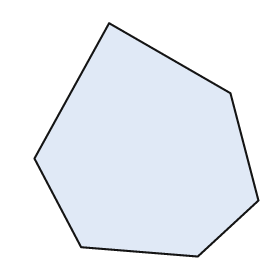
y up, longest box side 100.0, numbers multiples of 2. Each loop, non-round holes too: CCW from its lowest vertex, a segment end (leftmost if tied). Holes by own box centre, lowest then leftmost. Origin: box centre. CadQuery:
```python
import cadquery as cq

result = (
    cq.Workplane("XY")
    .moveTo(22.0, -50.0)
    .lineTo(48.0, -26.0)
    .lineTo(36.0, 20.0)
    .lineTo(-16.0, 50.0)
    .lineTo(-48.0, -8.0)
    .lineTo(-28.0, -46.0)
    .close()
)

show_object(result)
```